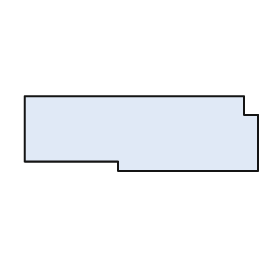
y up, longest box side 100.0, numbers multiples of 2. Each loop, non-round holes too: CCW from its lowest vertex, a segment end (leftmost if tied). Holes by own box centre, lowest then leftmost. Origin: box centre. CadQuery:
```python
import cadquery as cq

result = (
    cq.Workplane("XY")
    .moveTo(-10.0, -16.0)
    .lineTo(50.0, -16.0)
    .lineTo(50.0, 8.0)
    .lineTo(44.0, 8.0)
    .lineTo(44.0, 16.0)
    .lineTo(-50.0, 16.0)
    .lineTo(-50.0, -12.0)
    .lineTo(-10.0, -12.0)
    .close()
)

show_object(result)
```